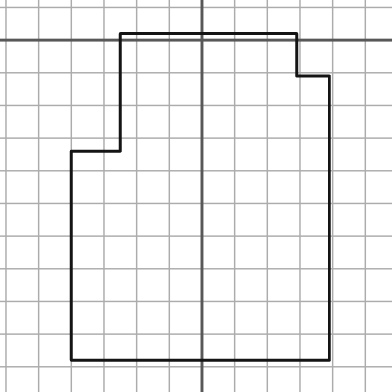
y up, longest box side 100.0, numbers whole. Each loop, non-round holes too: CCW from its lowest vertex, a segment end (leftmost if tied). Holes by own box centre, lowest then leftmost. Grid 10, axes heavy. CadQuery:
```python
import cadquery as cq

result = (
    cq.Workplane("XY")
    .moveTo(-40.0, -98.0)
    .lineTo(39.0, -98.0)
    .lineTo(39.0, -11.0)
    .lineTo(29.0, -11.0)
    .lineTo(29.0, 2.0)
    .lineTo(-25.0, 2.0)
    .lineTo(-25.0, -34.0)
    .lineTo(-40.0, -34.0)
    .close()
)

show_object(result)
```